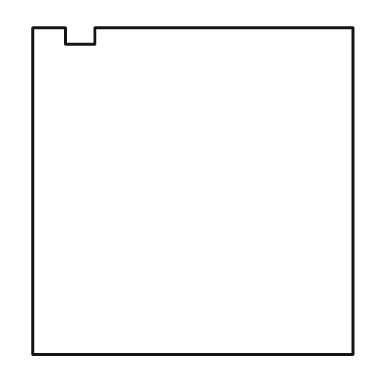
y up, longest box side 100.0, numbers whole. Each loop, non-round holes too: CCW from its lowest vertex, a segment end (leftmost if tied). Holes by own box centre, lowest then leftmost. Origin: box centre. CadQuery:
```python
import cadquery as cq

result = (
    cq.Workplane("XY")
    .moveTo(-49.0, -50.0)
    .lineTo(49.0, -50.0)
    .lineTo(49.0, 50.0)
    .lineTo(-30.0, 50.0)
    .lineTo(-30.0, 45.0)
    .lineTo(-39.0, 45.0)
    .lineTo(-39.0, 50.0)
    .lineTo(-49.0, 50.0)
    .close()
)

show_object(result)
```